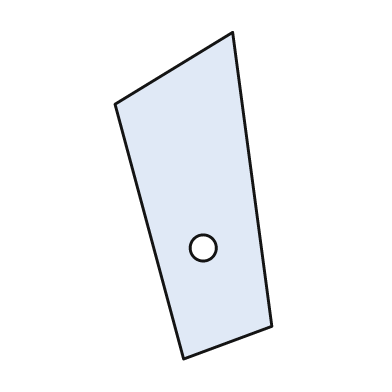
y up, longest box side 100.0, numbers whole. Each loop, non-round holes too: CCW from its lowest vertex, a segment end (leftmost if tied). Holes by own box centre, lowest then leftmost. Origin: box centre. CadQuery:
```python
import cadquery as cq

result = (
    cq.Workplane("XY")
    .moveTo(-3.0, -50.0)
    .lineTo(24.0, -40.0)
    .lineTo(12.0, 50.0)
    .lineTo(-24.0, 28.0)
    .close()
    .moveTo(3.0, -16.0)
    .circle(4.0)
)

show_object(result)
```